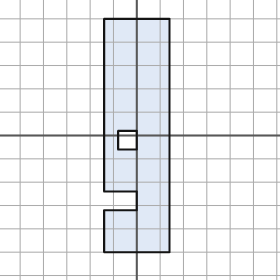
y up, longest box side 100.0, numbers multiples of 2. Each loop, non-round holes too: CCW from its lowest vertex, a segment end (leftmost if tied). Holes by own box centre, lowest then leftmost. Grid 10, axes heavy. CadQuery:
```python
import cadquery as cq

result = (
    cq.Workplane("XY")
    .moveTo(-14.0, -50.0)
    .lineTo(14.0, -50.0)
    .lineTo(14.0, 50.0)
    .lineTo(-14.0, 50.0)
    .lineTo(-14.0, -24.0)
    .lineTo(0.0, -24.0)
    .lineTo(0.0, -32.0)
    .lineTo(-14.0, -32.0)
    .close()
    .moveTo(-8.0, -6.0)
    .lineTo(0.0, -6.0)
    .lineTo(0.0, 2.0)
    .lineTo(-8.0, 2.0)
    .close()
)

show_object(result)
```